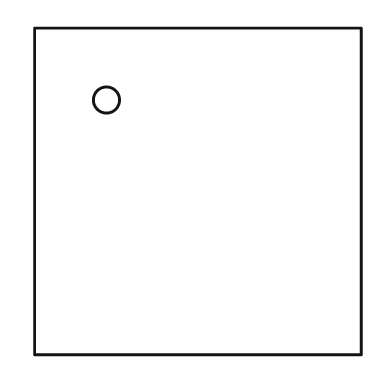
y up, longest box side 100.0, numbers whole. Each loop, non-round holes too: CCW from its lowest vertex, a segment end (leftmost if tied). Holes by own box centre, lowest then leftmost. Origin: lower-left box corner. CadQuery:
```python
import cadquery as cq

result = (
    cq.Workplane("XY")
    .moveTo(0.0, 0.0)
    .lineTo(100.0, 0.0)
    .lineTo(100.0, 100.0)
    .lineTo(0.0, 100.0)
    .close()
    .moveTo(22.0, 78.0)
    .circle(4.0)
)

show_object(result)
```